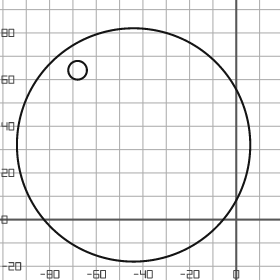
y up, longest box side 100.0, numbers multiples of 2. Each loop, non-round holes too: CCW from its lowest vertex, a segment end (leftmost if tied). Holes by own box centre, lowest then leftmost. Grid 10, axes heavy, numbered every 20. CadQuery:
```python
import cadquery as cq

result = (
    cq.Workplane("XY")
    .moveTo(-44.0, 32.0)
    .circle(50.0)
    .moveTo(-68.0, 64.0)
    .circle(4.0)
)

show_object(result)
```